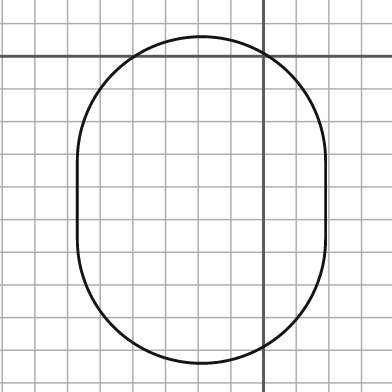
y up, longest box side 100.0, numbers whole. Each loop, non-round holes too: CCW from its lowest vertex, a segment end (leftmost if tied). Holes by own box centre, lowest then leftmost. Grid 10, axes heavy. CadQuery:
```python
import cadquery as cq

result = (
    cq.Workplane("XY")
    .moveTo(-57.0, -56.0)
    .threePointArc((-19.0, -94.0), (19.0, -56.0))
    .lineTo(19.0, -32.0)
    .threePointArc((-19.0, 6.0), (-57.0, -32.0))
    .close()
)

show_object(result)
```